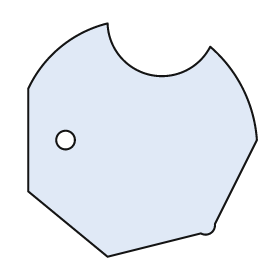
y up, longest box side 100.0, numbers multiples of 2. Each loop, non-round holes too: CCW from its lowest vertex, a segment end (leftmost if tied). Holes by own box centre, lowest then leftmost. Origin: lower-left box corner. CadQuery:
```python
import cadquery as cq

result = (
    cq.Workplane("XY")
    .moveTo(34.0, 0.0)
    .lineTo(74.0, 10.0)
    .threePointArc((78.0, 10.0), (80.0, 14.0))
    .lineTo(98.0, 50.0)
    .threePointArc((92.0, 72.0), (78.0, 90.0))
    .threePointArc((52.0, 78.0), (34.0, 100.0))
    .threePointArc((14.0, 90.0), (0.0, 72.0))
    .lineTo(0.0, 28.0)
    .close()
    .moveTo(16.0, 50.0)
    .circle(4.0)
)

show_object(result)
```